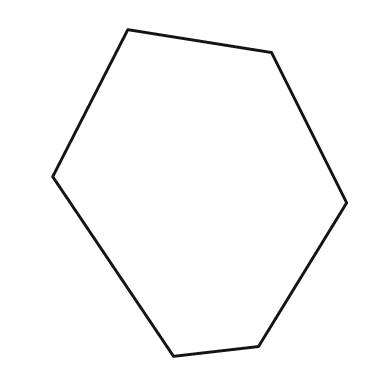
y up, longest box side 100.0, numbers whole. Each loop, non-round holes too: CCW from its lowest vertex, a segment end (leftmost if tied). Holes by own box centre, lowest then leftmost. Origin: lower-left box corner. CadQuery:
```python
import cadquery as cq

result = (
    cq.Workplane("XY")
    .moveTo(37.0, 0.0)
    .lineTo(63.0, 3.0)
    .lineTo(90.0, 47.0)
    .lineTo(67.0, 93.0)
    .lineTo(23.0, 100.0)
    .lineTo(0.0, 55.0)
    .close()
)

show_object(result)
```